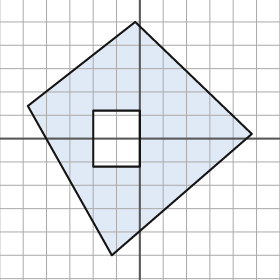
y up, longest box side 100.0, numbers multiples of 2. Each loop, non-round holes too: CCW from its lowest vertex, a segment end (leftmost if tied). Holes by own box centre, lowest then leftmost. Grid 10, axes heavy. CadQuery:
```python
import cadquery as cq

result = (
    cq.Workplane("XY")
    .moveTo(-12.0, -50.0)
    .lineTo(48.0, 2.0)
    .lineTo(-2.0, 50.0)
    .lineTo(-48.0, 14.0)
    .close()
    .moveTo(-20.0, -12.0)
    .lineTo(0.0, -12.0)
    .lineTo(0.0, 12.0)
    .lineTo(-20.0, 12.0)
    .close()
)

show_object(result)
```